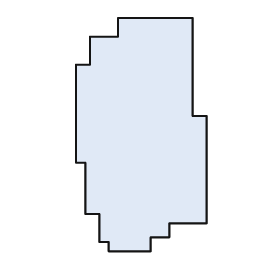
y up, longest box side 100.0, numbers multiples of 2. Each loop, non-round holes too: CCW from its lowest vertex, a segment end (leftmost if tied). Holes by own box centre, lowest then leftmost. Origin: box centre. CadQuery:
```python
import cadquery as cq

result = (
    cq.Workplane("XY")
    .moveTo(-14.0, -50.0)
    .lineTo(4.0, -50.0)
    .lineTo(4.0, -44.0)
    .lineTo(12.0, -44.0)
    .lineTo(12.0, -38.0)
    .lineTo(28.0, -38.0)
    .lineTo(28.0, 8.0)
    .lineTo(22.0, 8.0)
    .lineTo(22.0, 50.0)
    .lineTo(-10.0, 50.0)
    .lineTo(-10.0, 42.0)
    .lineTo(-22.0, 42.0)
    .lineTo(-22.0, 30.0)
    .lineTo(-28.0, 30.0)
    .lineTo(-28.0, -12.0)
    .lineTo(-24.0, -12.0)
    .lineTo(-24.0, -34.0)
    .lineTo(-18.0, -34.0)
    .lineTo(-18.0, -46.0)
    .lineTo(-14.0, -46.0)
    .close()
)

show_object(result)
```